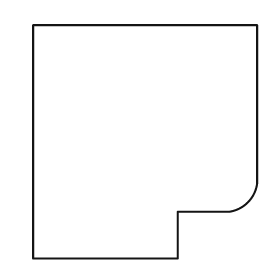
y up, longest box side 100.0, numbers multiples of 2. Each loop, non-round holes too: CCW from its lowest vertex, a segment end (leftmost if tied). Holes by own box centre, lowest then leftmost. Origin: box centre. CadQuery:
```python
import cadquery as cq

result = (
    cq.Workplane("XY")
    .moveTo(-48.0, -50.0)
    .lineTo(14.0, -50.0)
    .lineTo(14.0, -30.0)
    .lineTo(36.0, -30.0)
    .threePointArc((44.0, -26.0), (48.0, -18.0))
    .lineTo(48.0, 50.0)
    .lineTo(-48.0, 50.0)
    .close()
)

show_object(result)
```